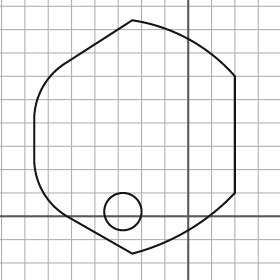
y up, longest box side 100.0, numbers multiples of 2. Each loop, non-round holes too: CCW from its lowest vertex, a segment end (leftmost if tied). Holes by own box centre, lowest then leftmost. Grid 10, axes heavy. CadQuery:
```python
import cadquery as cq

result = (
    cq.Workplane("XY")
    .moveTo(-24.0, -16.0)
    .threePointArc((0.0, -6.0), (20.0, 10.0))
    .lineTo(20.0, 60.0)
    .threePointArc((0.0, 76.0), (-24.0, 84.0))
    .lineTo(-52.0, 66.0)
    .threePointArc((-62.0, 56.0), (-66.0, 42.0))
    .lineTo(-66.0, 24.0)
    .threePointArc((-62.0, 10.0), (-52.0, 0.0))
    .close()
    .moveTo(-28.0, 2.0)
    .circle(8.0)
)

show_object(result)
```